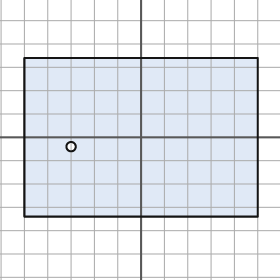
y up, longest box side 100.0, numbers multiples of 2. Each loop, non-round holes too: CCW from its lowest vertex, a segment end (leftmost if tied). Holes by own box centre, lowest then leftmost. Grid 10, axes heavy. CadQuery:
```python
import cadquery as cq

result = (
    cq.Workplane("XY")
    .moveTo(-50.0, -34.0)
    .lineTo(50.0, -34.0)
    .lineTo(50.0, 34.0)
    .lineTo(-50.0, 34.0)
    .close()
    .moveTo(-30.0, -4.0)
    .circle(2.0)
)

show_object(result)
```